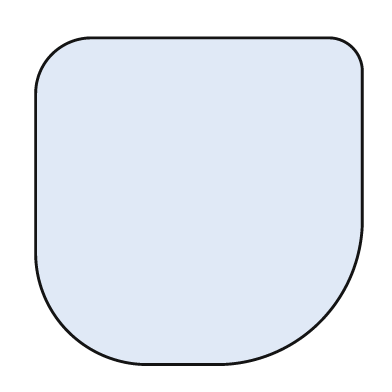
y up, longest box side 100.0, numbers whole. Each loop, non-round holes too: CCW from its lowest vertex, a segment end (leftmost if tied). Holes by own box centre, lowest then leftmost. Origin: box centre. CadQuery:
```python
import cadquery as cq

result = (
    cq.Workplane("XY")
    .moveTo(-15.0, -50.0)
    .lineTo(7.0, -50.0)
    .threePointArc((37.0, -37.0), (50.0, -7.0))
    .lineTo(50.0, 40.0)
    .threePointArc((47.0, 47.0), (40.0, 50.0))
    .lineTo(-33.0, 50.0)
    .threePointArc((-45.0, 45.0), (-50.0, 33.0))
    .lineTo(-50.0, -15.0)
    .threePointArc((-40.0, -40.0), (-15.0, -50.0))
    .close()
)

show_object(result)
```